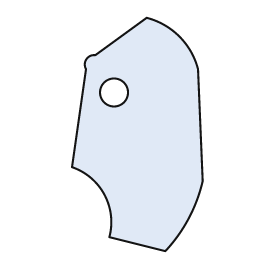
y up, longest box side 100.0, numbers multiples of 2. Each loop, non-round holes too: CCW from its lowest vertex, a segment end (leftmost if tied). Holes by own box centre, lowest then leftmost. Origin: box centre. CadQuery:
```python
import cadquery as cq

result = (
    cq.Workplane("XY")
    .moveTo(12.0, -50.0)
    .threePointArc((22.0, -36.0), (28.0, -20.0))
    .lineTo(26.0, 28.0)
    .threePointArc((18.0, 42.0), (4.0, 50.0))
    .lineTo(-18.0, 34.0)
    .threePointArc((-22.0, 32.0), (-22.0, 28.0))
    .lineTo(-28.0, -14.0)
    .threePointArc((-14.0, -26.0), (-12.0, -44.0))
    .close()
    .moveTo(-10.0, 18.0)
    .circle(6.0)
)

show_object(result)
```